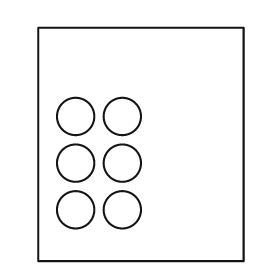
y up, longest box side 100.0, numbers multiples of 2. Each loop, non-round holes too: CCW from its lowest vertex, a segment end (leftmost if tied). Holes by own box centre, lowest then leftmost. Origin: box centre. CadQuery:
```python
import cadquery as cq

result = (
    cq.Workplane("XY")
    .moveTo(-44.0, -50.0)
    .lineTo(44.0, -50.0)
    .lineTo(44.0, 50.0)
    .lineTo(-44.0, 50.0)
    .close()
    .moveTo(-28.0, -28.0)
    .circle(8.0)
    .moveTo(-8.0, -28.0)
    .circle(8.0)
    .moveTo(-28.0, -8.0)
    .circle(8.0)
    .moveTo(-8.0, -8.0)
    .circle(8.0)
    .moveTo(-28.0, 12.0)
    .circle(8.0)
    .moveTo(-8.0, 12.0)
    .circle(8.0)
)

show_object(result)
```